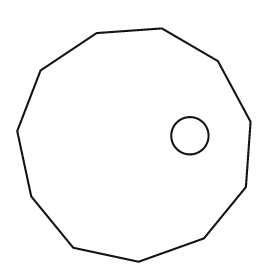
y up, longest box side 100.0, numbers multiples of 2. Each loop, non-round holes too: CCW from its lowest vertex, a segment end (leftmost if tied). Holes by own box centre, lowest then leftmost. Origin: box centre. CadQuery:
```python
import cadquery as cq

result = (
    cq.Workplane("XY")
    .moveTo(2.0, -50.0)
    .lineTo(30.0, -40.0)
    .lineTo(48.0, -18.0)
    .lineTo(50.0, 10.0)
    .lineTo(36.0, 36.0)
    .lineTo(12.0, 50.0)
    .lineTo(-16.0, 48.0)
    .lineTo(-40.0, 32.0)
    .lineTo(-50.0, 6.0)
    .lineTo(-44.0, -22.0)
    .lineTo(-26.0, -44.0)
    .close()
    .moveTo(24.0, 4.0)
    .circle(8.0)
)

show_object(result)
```